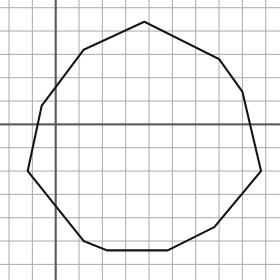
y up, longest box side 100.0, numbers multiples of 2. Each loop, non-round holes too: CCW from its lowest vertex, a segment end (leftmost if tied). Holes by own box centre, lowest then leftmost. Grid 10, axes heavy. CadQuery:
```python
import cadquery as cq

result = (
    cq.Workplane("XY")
    .moveTo(22.0, -54.0)
    .lineTo(48.0, -54.0)
    .lineTo(68.0, -44.0)
    .lineTo(88.0, -20.0)
    .lineTo(80.0, 14.0)
    .lineTo(70.0, 28.0)
    .lineTo(38.0, 44.0)
    .lineTo(12.0, 32.0)
    .lineTo(-6.0, 8.0)
    .lineTo(-12.0, -20.0)
    .lineTo(12.0, -50.0)
    .close()
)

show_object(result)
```